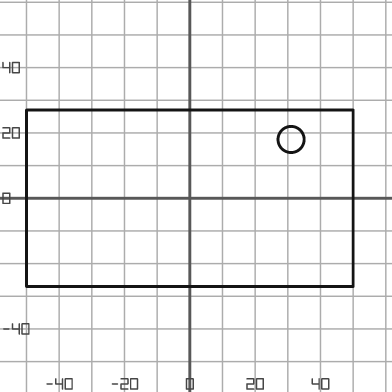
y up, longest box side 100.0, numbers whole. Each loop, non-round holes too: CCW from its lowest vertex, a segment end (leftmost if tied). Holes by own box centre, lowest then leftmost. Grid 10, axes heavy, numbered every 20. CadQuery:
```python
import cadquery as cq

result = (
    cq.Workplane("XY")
    .moveTo(-50.0, -27.0)
    .lineTo(50.0, -27.0)
    .lineTo(50.0, 27.0)
    .lineTo(-50.0, 27.0)
    .close()
    .moveTo(31.0, 18.0)
    .circle(4.0)
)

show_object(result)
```